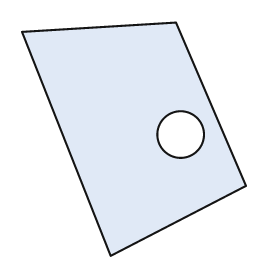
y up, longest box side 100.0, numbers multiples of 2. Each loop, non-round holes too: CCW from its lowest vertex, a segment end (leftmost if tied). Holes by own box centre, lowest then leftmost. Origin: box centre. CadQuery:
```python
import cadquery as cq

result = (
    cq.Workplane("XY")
    .moveTo(-10.0, -50.0)
    .lineTo(48.0, -20.0)
    .lineTo(18.0, 50.0)
    .lineTo(-48.0, 46.0)
    .close()
    .moveTo(20.0, 2.0)
    .circle(10.0)
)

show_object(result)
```